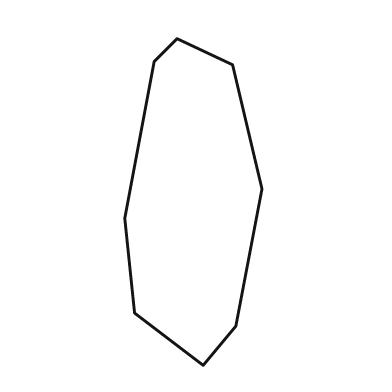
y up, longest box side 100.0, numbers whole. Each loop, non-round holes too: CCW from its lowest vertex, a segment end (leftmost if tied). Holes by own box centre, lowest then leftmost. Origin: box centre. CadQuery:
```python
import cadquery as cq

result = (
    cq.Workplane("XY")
    .moveTo(3.0, -50.0)
    .lineTo(13.0, -38.0)
    .lineTo(21.0, 4.0)
    .lineTo(12.0, 42.0)
    .lineTo(-5.0, 50.0)
    .lineTo(-12.0, 43.0)
    .lineTo(-21.0, -5.0)
    .lineTo(-18.0, -34.0)
    .close()
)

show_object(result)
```